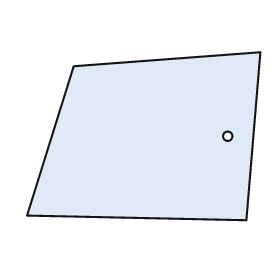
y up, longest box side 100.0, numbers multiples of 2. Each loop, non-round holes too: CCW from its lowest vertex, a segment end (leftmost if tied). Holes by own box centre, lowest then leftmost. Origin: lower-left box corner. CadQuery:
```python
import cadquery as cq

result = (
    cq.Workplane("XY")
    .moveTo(94.0, 0.0)
    .lineTo(100.0, 72.0)
    .lineTo(20.0, 66.0)
    .lineTo(0.0, 2.0)
    .close()
    .moveTo(86.0, 36.0)
    .circle(2.0)
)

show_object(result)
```